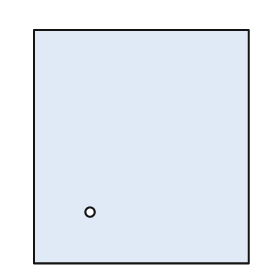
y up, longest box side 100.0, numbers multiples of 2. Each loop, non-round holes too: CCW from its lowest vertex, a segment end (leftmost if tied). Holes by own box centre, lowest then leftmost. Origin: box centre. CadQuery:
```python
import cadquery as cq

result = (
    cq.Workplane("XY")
    .moveTo(-46.0, -50.0)
    .lineTo(46.0, -50.0)
    .lineTo(46.0, 50.0)
    .lineTo(-46.0, 50.0)
    .close()
    .moveTo(-22.0, -28.0)
    .circle(2.0)
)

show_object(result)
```